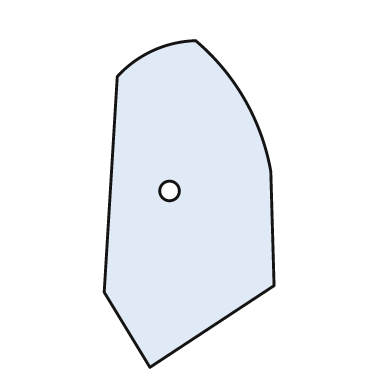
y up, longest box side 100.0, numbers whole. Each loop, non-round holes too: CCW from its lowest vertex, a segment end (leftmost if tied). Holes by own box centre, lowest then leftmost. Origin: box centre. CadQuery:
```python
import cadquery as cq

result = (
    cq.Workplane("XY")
    .moveTo(-12.0, -50.0)
    .lineTo(26.0, -25.0)
    .lineTo(25.0, 10.0)
    .threePointArc((17.0, 32.0), (2.0, 50.0))
    .threePointArc((-11.0, 47.0), (-22.0, 39.0))
    .lineTo(-26.0, -27.0)
    .close()
    .moveTo(-6.0, 4.0)
    .circle(3.0)
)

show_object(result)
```